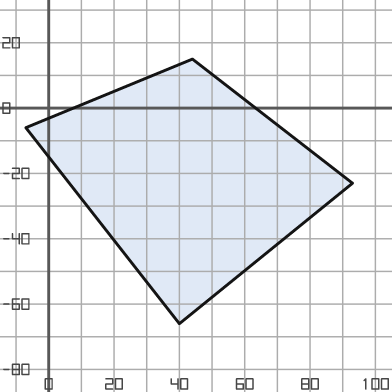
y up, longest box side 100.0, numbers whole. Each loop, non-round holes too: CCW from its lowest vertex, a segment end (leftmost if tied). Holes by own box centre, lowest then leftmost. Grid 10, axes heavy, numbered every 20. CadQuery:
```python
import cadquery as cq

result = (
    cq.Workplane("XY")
    .moveTo(40.0, -66.0)
    .lineTo(93.0, -23.0)
    .lineTo(44.0, 15.0)
    .lineTo(-7.0, -6.0)
    .close()
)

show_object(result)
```